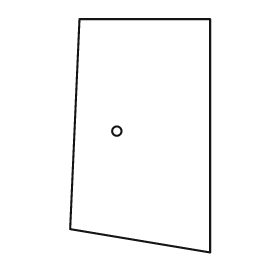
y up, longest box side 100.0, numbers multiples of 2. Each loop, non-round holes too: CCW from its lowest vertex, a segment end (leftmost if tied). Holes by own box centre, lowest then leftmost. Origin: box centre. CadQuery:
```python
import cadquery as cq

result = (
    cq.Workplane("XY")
    .moveTo(30.0, -50.0)
    .lineTo(30.0, 50.0)
    .lineTo(-26.0, 50.0)
    .lineTo(-30.0, -40.0)
    .close()
    .moveTo(-10.0, 2.0)
    .circle(2.0)
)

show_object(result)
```